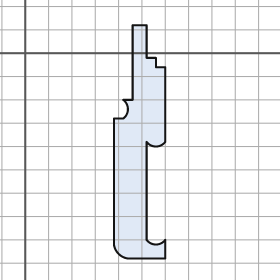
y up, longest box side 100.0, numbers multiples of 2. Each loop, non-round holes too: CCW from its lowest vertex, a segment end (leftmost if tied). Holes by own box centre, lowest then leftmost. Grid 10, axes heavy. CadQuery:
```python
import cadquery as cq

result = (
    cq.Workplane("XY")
    .moveTo(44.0, -88.0)
    .lineTo(60.0, -88.0)
    .lineTo(60.0, -80.0)
    .threePointArc((56.0, -82.0), (52.0, -80.0))
    .lineTo(52.0, -38.0)
    .threePointArc((56.0, -40.0), (60.0, -38.0))
    .lineTo(60.0, -6.0)
    .lineTo(56.0, -6.0)
    .lineTo(56.0, -2.0)
    .lineTo(52.0, -2.0)
    .lineTo(52.0, 12.0)
    .lineTo(46.0, 12.0)
    .lineTo(46.0, -20.0)
    .lineTo(42.0, -20.0)
    .threePointArc((44.0, -24.0), (42.0, -28.0))
    .lineTo(38.0, -28.0)
    .lineTo(38.0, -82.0)
    .threePointArc((40.0, -86.0), (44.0, -88.0))
    .close()
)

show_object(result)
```